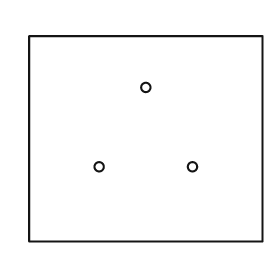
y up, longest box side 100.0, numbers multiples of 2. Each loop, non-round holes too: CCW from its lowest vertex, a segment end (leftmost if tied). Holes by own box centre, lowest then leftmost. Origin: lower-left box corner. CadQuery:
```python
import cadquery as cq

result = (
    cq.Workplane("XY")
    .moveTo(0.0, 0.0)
    .lineTo(100.0, 0.0)
    .lineTo(100.0, 88.0)
    .lineTo(0.0, 88.0)
    .close()
    .moveTo(30.0, 32.0)
    .circle(2.0)
    .moveTo(70.0, 32.0)
    .circle(2.0)
    .moveTo(50.0, 66.0)
    .circle(2.0)
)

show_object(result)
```